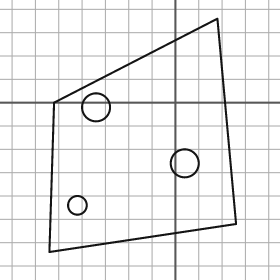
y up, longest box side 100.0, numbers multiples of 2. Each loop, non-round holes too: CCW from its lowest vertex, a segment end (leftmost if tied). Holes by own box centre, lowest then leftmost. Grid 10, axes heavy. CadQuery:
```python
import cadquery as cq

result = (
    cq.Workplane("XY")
    .moveTo(-54.0, -64.0)
    .lineTo(26.0, -52.0)
    .lineTo(18.0, 36.0)
    .lineTo(-52.0, 0.0)
    .close()
    .moveTo(-42.0, -44.0)
    .circle(4.0)
    .moveTo(4.0, -26.0)
    .circle(6.0)
    .moveTo(-34.0, -2.0)
    .circle(6.0)
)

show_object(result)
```